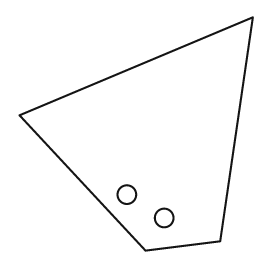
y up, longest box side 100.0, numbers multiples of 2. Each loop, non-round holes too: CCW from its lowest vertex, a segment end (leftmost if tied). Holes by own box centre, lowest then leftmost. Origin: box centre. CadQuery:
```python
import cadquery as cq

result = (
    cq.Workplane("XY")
    .moveTo(4.0, -50.0)
    .lineTo(36.0, -46.0)
    .lineTo(50.0, 50.0)
    .lineTo(-50.0, 8.0)
    .close()
    .moveTo(12.0, -36.0)
    .circle(4.0)
    .moveTo(-4.0, -26.0)
    .circle(4.0)
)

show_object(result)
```